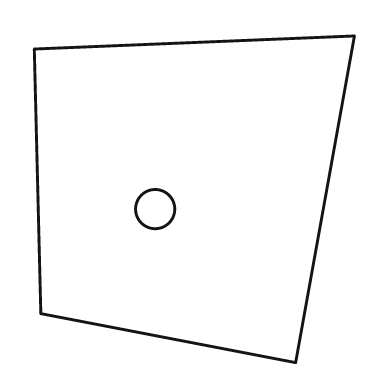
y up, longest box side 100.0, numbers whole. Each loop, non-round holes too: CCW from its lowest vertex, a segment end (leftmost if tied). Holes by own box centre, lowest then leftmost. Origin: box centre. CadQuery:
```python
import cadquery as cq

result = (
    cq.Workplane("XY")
    .moveTo(31.0, -50.0)
    .lineTo(49.0, 50.0)
    .lineTo(-49.0, 46.0)
    .lineTo(-47.0, -35.0)
    .close()
    .moveTo(-12.0, -3.0)
    .circle(6.0)
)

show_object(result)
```